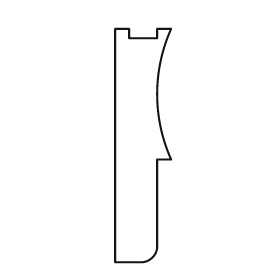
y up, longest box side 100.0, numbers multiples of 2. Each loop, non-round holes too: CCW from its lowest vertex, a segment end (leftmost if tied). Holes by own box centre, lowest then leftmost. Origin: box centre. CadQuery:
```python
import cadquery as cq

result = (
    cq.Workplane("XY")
    .moveTo(-12.0, -50.0)
    .lineTo(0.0, -50.0)
    .threePointArc((4.0, -48.0), (6.0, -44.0))
    .lineTo(6.0, -6.0)
    .lineTo(12.0, -6.0)
    .threePointArc((6.0, 22.0), (12.0, 50.0))
    .lineTo(6.0, 50.0)
    .lineTo(6.0, 46.0)
    .lineTo(-6.0, 46.0)
    .lineTo(-6.0, 50.0)
    .lineTo(-12.0, 50.0)
    .close()
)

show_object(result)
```